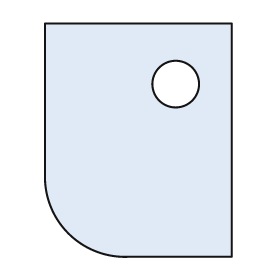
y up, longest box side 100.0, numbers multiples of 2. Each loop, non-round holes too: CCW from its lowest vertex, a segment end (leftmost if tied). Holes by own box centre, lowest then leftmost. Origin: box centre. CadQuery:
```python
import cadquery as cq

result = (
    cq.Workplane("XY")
    .moveTo(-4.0, -50.0)
    .lineTo(40.0, -50.0)
    .lineTo(40.0, 50.0)
    .lineTo(-40.0, 50.0)
    .lineTo(-40.0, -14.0)
    .threePointArc((-30.0, -40.0), (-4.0, -50.0))
    .close()
    .moveTo(16.0, 24.0)
    .circle(10.0)
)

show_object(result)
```